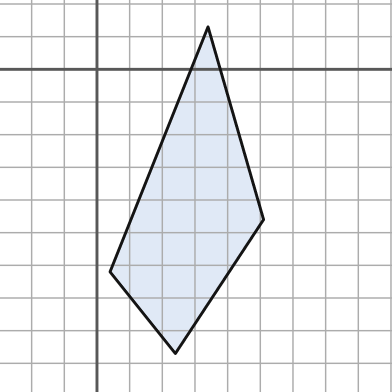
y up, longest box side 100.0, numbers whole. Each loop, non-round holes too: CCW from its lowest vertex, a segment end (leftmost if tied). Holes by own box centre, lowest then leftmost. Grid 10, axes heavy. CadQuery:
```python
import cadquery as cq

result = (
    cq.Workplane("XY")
    .moveTo(24.0, -87.0)
    .lineTo(51.0, -46.0)
    .lineTo(34.0, 13.0)
    .lineTo(4.0, -62.0)
    .close()
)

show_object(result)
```